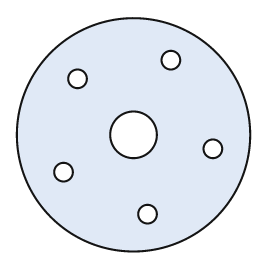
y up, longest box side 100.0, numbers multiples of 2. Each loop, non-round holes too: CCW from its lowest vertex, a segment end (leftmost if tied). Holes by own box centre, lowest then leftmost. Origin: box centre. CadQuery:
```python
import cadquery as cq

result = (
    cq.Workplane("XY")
    .moveTo(0.0, 0.0)
    .circle(50.0)
    .moveTo(6.0, -34.0)
    .circle(4.0)
    .moveTo(-30.0, -16.0)
    .circle(4.0)
    .moveTo(34.0, -6.0)
    .circle(4.0)
    .moveTo(0.0, 0.0)
    .circle(10.0)
    .moveTo(-24.0, 24.0)
    .circle(4.0)
    .moveTo(16.0, 32.0)
    .circle(4.0)
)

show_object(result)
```